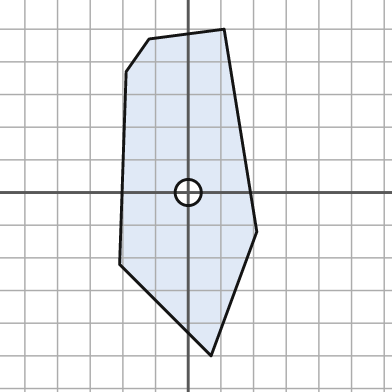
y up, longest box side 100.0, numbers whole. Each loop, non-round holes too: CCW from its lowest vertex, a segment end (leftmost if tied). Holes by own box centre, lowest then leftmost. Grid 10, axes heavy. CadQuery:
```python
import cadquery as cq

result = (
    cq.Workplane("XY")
    .moveTo(7.0, -50.0)
    .lineTo(21.0, -12.0)
    .lineTo(11.0, 50.0)
    .lineTo(-12.0, 47.0)
    .lineTo(-19.0, 37.0)
    .lineTo(-21.0, -22.0)
    .close()
    .moveTo(0.0, 0.0)
    .circle(4.0)
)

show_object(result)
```